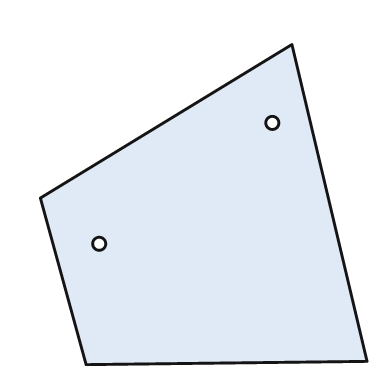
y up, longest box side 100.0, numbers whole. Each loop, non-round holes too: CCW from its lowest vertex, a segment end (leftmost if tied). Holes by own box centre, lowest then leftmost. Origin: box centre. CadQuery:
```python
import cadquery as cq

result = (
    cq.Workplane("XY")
    .moveTo(-36.0, -49.0)
    .lineTo(50.0, -48.0)
    .lineTo(27.0, 49.0)
    .lineTo(-50.0, 2.0)
    .close()
    .moveTo(-32.0, -12.0)
    .circle(2.0)
    .moveTo(21.0, 25.0)
    .circle(2.0)
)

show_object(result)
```